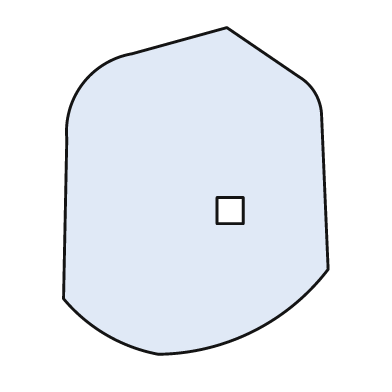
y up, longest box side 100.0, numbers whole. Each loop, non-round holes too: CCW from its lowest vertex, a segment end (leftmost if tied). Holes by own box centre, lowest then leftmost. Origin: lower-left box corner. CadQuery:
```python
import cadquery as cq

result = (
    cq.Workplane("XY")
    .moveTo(29.0, 0.0)
    .threePointArc((58.0, 7.0), (81.0, 26.0))
    .lineTo(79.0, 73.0)
    .threePointArc((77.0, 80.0), (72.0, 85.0))
    .lineTo(50.0, 100.0)
    .lineTo(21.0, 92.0)
    .threePointArc((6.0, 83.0), (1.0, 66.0))
    .lineTo(0.0, 17.0)
    .threePointArc((13.0, 6.0), (29.0, 0.0))
    .close()
    .moveTo(47.0, 40.0)
    .lineTo(55.0, 40.0)
    .lineTo(55.0, 48.0)
    .lineTo(47.0, 48.0)
    .close()
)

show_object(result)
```